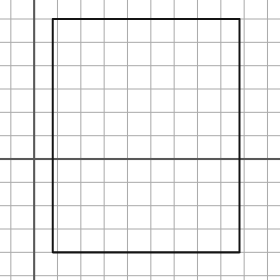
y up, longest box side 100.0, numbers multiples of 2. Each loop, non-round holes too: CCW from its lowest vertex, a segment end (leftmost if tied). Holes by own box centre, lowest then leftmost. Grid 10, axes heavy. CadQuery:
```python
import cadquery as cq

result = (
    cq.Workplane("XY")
    .moveTo(8.0, -40.0)
    .lineTo(88.0, -40.0)
    .lineTo(88.0, 60.0)
    .lineTo(8.0, 60.0)
    .close()
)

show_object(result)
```